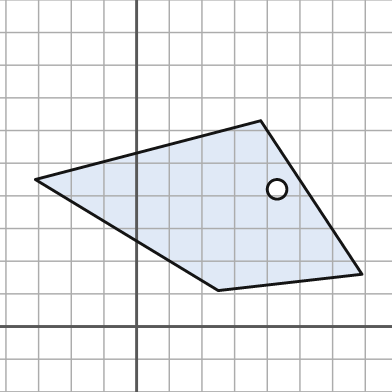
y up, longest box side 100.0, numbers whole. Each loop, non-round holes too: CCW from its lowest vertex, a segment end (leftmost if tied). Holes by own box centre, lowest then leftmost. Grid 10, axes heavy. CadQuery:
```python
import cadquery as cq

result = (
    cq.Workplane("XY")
    .moveTo(25.0, 11.0)
    .lineTo(69.0, 16.0)
    .lineTo(38.0, 63.0)
    .lineTo(-31.0, 45.0)
    .close()
    .moveTo(43.0, 42.0)
    .circle(3.0)
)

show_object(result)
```